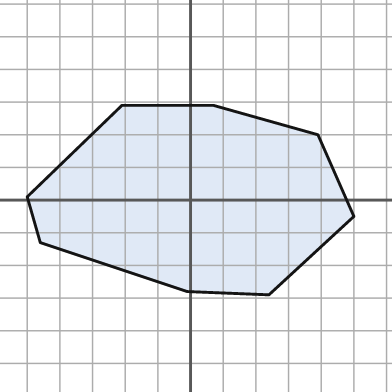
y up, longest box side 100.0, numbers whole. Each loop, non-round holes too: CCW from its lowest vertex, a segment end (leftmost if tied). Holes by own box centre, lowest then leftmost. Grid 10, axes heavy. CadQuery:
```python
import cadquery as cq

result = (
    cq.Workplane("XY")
    .moveTo(24.0, -29.0)
    .lineTo(50.0, -5.0)
    .lineTo(39.0, 20.0)
    .lineTo(7.0, 29.0)
    .lineTo(-21.0, 29.0)
    .lineTo(-50.0, 1.0)
    .lineTo(-46.0, -13.0)
    .lineTo(-1.0, -28.0)
    .close()
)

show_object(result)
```